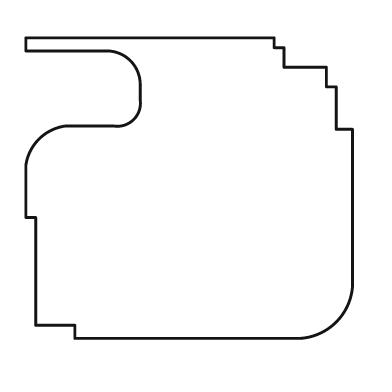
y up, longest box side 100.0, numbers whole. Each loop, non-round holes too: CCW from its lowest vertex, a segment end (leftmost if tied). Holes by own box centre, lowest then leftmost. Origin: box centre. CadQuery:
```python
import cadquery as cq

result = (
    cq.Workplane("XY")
    .moveTo(-35.0, -46.0)
    .lineTo(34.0, -46.0)
    .threePointArc((45.0, -41.0), (50.0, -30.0))
    .lineTo(50.0, 18.0)
    .lineTo(45.0, 18.0)
    .lineTo(45.0, 31.0)
    .lineTo(42.0, 31.0)
    .lineTo(42.0, 37.0)
    .lineTo(29.0, 37.0)
    .lineTo(29.0, 43.0)
    .lineTo(26.0, 43.0)
    .lineTo(26.0, 46.0)
    .lineTo(-50.0, 46.0)
    .lineTo(-50.0, 42.0)
    .lineTo(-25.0, 42.0)
    .threePointArc((-18.0, 39.0), (-15.0, 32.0))
    .lineTo(-15.0, 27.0)
    .threePointArc((-17.0, 21.0), (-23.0, 19.0))
    .lineTo(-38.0, 19.0)
    .threePointArc((-46.0, 15.0), (-50.0, 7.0))
    .lineTo(-50.0, -9.0)
    .lineTo(-47.0, -9.0)
    .lineTo(-47.0, -42.0)
    .lineTo(-35.0, -42.0)
    .close()
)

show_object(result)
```